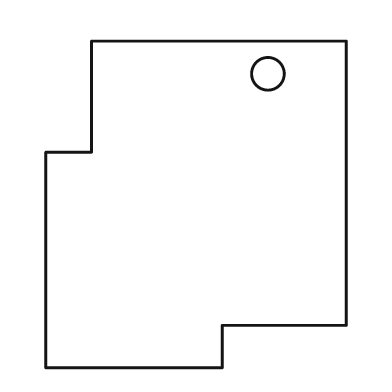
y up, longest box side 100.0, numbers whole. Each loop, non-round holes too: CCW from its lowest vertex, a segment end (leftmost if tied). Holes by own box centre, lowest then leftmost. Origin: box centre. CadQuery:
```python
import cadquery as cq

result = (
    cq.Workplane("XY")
    .moveTo(-46.0, -50.0)
    .lineTo(8.0, -50.0)
    .lineTo(8.0, -37.0)
    .lineTo(46.0, -37.0)
    .lineTo(46.0, 50.0)
    .lineTo(-32.0, 50.0)
    .lineTo(-32.0, 16.0)
    .lineTo(-46.0, 16.0)
    .close()
    .moveTo(22.0, 40.0)
    .circle(5.0)
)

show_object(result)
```